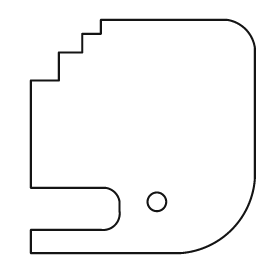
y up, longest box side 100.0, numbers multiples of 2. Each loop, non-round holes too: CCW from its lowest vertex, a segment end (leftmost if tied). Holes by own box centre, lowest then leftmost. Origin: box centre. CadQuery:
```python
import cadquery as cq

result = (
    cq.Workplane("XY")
    .moveTo(-48.0, -50.0)
    .lineTo(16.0, -50.0)
    .threePointArc((38.0, -40.0), (48.0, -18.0))
    .lineTo(48.0, 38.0)
    .threePointArc((44.0, 46.0), (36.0, 50.0))
    .lineTo(-18.0, 50.0)
    .lineTo(-18.0, 44.0)
    .lineTo(-26.0, 44.0)
    .lineTo(-26.0, 36.0)
    .lineTo(-36.0, 36.0)
    .lineTo(-36.0, 24.0)
    .lineTo(-48.0, 24.0)
    .lineTo(-48.0, -22.0)
    .lineTo(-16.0, -22.0)
    .threePointArc((-12.0, -24.0), (-10.0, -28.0))
    .lineTo(-10.0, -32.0)
    .threePointArc((-12.0, -38.0), (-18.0, -40.0))
    .lineTo(-48.0, -40.0)
    .close()
    .moveTo(6.0, -28.0)
    .circle(4.0)
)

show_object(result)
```